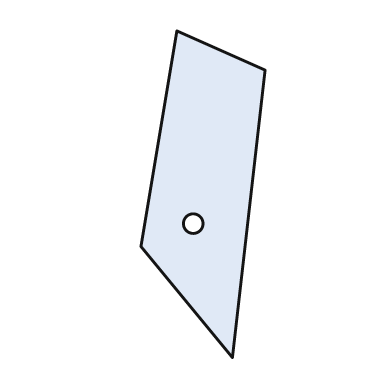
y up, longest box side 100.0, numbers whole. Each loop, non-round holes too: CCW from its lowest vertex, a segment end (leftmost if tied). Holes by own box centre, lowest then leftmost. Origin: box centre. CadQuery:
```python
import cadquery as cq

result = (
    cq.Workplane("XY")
    .moveTo(9.0, -50.0)
    .lineTo(19.0, 38.0)
    .lineTo(-8.0, 50.0)
    .lineTo(-19.0, -16.0)
    .close()
    .moveTo(-3.0, -9.0)
    .circle(3.0)
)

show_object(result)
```